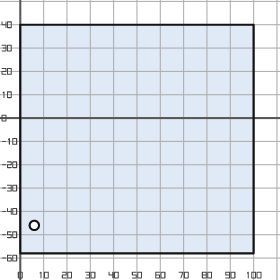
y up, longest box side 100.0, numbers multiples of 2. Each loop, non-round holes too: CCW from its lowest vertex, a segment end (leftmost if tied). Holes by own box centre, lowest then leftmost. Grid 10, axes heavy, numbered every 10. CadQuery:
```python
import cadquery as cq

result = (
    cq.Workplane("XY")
    .moveTo(0.0, -58.0)
    .lineTo(100.0, -58.0)
    .lineTo(100.0, 40.0)
    .lineTo(0.0, 40.0)
    .close()
    .moveTo(6.0, -46.0)
    .circle(2.0)
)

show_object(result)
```